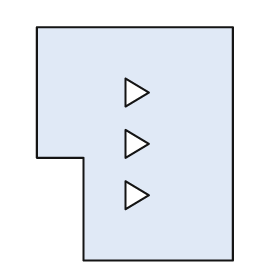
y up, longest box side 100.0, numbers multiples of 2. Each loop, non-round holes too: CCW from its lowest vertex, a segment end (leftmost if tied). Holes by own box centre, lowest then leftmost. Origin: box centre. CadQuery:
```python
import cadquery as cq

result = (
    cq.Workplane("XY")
    .moveTo(-22.0, -50.0)
    .lineTo(42.0, -50.0)
    .lineTo(42.0, 50.0)
    .lineTo(-42.0, 50.0)
    .lineTo(-42.0, -6.0)
    .lineTo(-22.0, -6.0)
    .close()
    .moveTo(-4.0, -28.0)
    .lineTo(6.0, -22.0)
    .lineTo(-4.0, -16.0)
    .close()
    .moveTo(-4.0, -6.0)
    .lineTo(6.0, 0.0)
    .lineTo(-4.0, 6.0)
    .close()
    .moveTo(-4.0, 16.0)
    .lineTo(6.0, 22.0)
    .lineTo(-4.0, 28.0)
    .close()
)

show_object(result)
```